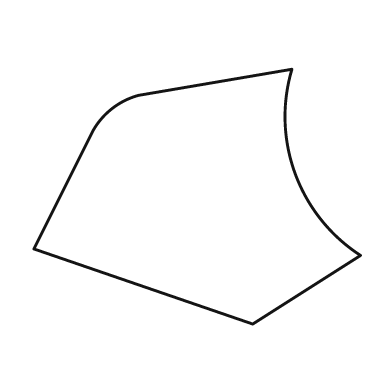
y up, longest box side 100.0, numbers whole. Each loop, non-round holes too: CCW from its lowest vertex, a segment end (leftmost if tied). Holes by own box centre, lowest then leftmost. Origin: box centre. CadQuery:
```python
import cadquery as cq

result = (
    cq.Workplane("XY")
    .moveTo(17.0, -39.0)
    .lineTo(50.0, -18.0)
    .threePointArc((30.0, 7.0), (29.0, 39.0))
    .lineTo(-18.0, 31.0)
    .threePointArc((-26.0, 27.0), (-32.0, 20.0))
    .lineTo(-50.0, -16.0)
    .close()
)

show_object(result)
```